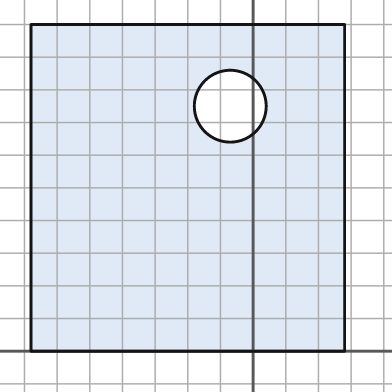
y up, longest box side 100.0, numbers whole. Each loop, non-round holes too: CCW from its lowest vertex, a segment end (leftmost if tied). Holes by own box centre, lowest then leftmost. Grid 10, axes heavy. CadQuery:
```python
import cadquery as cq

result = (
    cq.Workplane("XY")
    .moveTo(-68.0, 0.0)
    .lineTo(28.0, 0.0)
    .lineTo(28.0, 100.0)
    .lineTo(-68.0, 100.0)
    .close()
    .moveTo(-7.0, 75.0)
    .circle(11.0)
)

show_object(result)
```